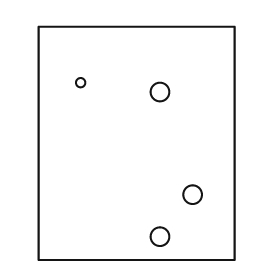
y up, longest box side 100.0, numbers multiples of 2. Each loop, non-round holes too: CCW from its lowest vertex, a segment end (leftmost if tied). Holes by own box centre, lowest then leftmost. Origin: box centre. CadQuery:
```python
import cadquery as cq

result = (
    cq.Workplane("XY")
    .moveTo(-42.0, -50.0)
    .lineTo(42.0, -50.0)
    .lineTo(42.0, 50.0)
    .lineTo(-42.0, 50.0)
    .close()
    .moveTo(10.0, -40.0)
    .circle(4.0)
    .moveTo(24.0, -22.0)
    .circle(4.0)
    .moveTo(10.0, 22.0)
    .circle(4.0)
    .moveTo(-24.0, 26.0)
    .circle(2.0)
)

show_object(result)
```